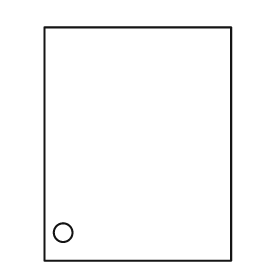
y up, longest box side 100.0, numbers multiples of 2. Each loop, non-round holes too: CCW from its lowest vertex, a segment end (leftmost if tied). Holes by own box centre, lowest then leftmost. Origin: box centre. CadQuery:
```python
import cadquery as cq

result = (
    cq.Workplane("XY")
    .moveTo(-40.0, -50.0)
    .lineTo(40.0, -50.0)
    .lineTo(40.0, 50.0)
    .lineTo(-40.0, 50.0)
    .close()
    .moveTo(-32.0, -38.0)
    .circle(4.0)
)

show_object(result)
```